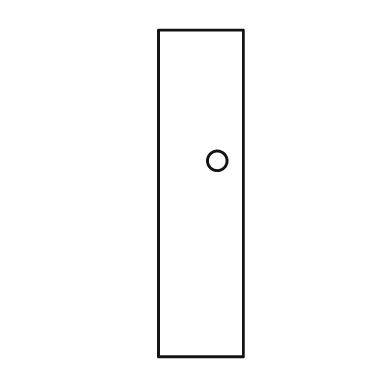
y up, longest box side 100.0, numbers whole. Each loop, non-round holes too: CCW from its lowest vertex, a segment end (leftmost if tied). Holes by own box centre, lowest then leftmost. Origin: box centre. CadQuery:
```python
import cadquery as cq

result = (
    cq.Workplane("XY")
    .moveTo(-13.0, -50.0)
    .lineTo(13.0, -50.0)
    .lineTo(13.0, 50.0)
    .lineTo(-13.0, 50.0)
    .close()
    .moveTo(5.0, 10.0)
    .circle(3.0)
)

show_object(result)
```